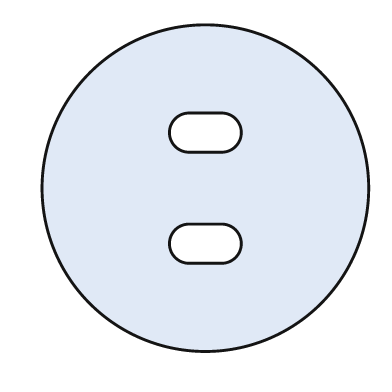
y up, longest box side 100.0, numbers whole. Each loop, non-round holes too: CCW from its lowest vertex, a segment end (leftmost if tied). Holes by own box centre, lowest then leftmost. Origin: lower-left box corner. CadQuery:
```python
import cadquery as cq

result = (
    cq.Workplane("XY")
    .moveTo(50.0, 50.0)
    .circle(50.0)
    .moveTo(45.0, 27.0)
    .lineTo(55.0, 27.0)
    .threePointArc((61.0, 33.0), (55.0, 39.0))
    .lineTo(45.0, 39.0)
    .threePointArc((39.0, 33.0), (45.0, 27.0))
    .close()
    .moveTo(45.0, 61.0)
    .lineTo(55.0, 61.0)
    .threePointArc((61.0, 67.0), (55.0, 73.0))
    .lineTo(45.0, 73.0)
    .threePointArc((39.0, 67.0), (45.0, 61.0))
    .close()
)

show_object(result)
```